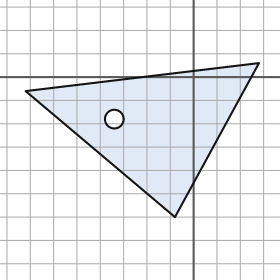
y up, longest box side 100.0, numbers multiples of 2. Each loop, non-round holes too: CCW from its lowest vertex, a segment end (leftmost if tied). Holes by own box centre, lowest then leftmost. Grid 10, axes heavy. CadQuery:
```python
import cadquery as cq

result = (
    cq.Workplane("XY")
    .moveTo(-8.0, -60.0)
    .lineTo(28.0, 6.0)
    .lineTo(-72.0, -6.0)
    .close()
    .moveTo(-34.0, -18.0)
    .circle(4.0)
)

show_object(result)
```